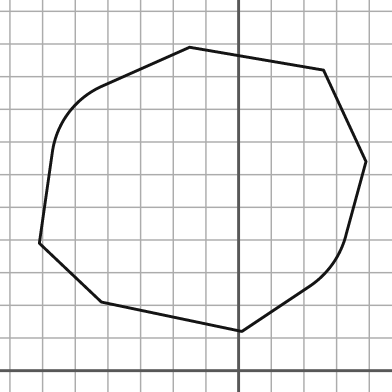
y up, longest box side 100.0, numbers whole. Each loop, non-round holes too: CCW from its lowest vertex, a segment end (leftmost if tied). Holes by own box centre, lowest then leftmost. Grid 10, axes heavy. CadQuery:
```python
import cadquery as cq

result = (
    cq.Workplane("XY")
    .moveTo(1.0, 12.0)
    .lineTo(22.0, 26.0)
    .threePointArc((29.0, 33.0), (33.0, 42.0))
    .lineTo(39.0, 64.0)
    .lineTo(26.0, 92.0)
    .lineTo(-15.0, 99.0)
    .lineTo(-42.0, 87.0)
    .threePointArc((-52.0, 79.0), (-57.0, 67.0))
    .lineTo(-61.0, 39.0)
    .lineTo(-42.0, 21.0)
    .close()
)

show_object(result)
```